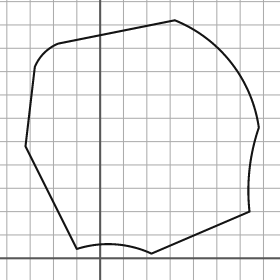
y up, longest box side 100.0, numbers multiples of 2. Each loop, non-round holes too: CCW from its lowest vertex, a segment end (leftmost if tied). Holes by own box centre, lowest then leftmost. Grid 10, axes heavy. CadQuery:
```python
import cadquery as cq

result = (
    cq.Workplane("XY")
    .moveTo(22.0, 2.0)
    .lineTo(64.0, 20.0)
    .threePointArc((64.0, 38.0), (68.0, 56.0))
    .threePointArc((56.0, 84.0), (32.0, 102.0))
    .lineTo(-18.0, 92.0)
    .threePointArc((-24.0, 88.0), (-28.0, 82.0))
    .lineTo(-32.0, 48.0)
    .lineTo(-10.0, 4.0)
    .threePointArc((6.0, 6.0), (22.0, 2.0))
    .close()
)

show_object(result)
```